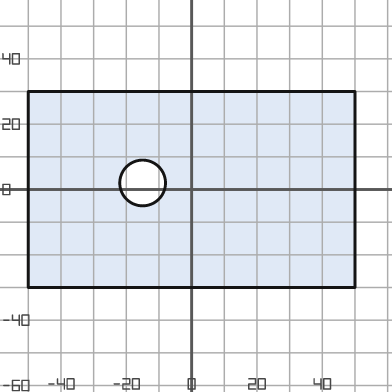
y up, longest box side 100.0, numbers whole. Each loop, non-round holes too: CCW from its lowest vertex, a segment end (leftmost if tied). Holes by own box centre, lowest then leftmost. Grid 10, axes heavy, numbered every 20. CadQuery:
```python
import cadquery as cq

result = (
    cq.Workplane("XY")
    .moveTo(-50.0, -30.0)
    .lineTo(50.0, -30.0)
    .lineTo(50.0, 30.0)
    .lineTo(-50.0, 30.0)
    .close()
    .moveTo(-15.0, 2.0)
    .circle(7.0)
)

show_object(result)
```